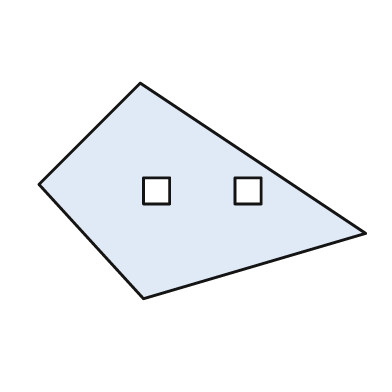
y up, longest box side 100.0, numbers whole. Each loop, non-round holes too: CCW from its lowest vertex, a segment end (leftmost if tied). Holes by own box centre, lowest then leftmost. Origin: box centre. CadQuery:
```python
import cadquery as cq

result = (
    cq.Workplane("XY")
    .moveTo(-18.0, -33.0)
    .lineTo(50.0, -13.0)
    .lineTo(-19.0, 33.0)
    .lineTo(-50.0, 2.0)
    .close()
    .moveTo(-18.0, -4.0)
    .lineTo(-10.0, -4.0)
    .lineTo(-10.0, 4.0)
    .lineTo(-18.0, 4.0)
    .close()
    .moveTo(10.0, -4.0)
    .lineTo(18.0, -4.0)
    .lineTo(18.0, 4.0)
    .lineTo(10.0, 4.0)
    .close()
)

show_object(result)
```